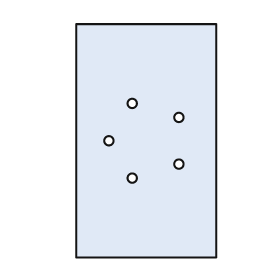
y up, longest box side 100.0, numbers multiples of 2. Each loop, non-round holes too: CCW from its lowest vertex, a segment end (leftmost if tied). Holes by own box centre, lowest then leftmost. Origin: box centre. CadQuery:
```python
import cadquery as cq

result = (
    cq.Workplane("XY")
    .moveTo(-30.0, -50.0)
    .lineTo(30.0, -50.0)
    .lineTo(30.0, 50.0)
    .lineTo(-30.0, 50.0)
    .close()
    .moveTo(-6.0, -16.0)
    .circle(2.0)
    .moveTo(14.0, -10.0)
    .circle(2.0)
    .moveTo(-16.0, 0.0)
    .circle(2.0)
    .moveTo(14.0, 10.0)
    .circle(2.0)
    .moveTo(-6.0, 16.0)
    .circle(2.0)
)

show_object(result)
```